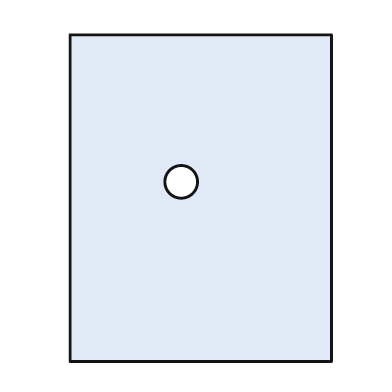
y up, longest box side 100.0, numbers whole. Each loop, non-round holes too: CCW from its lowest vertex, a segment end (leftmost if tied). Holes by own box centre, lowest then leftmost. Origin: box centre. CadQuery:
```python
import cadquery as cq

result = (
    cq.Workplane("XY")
    .moveTo(-40.0, -50.0)
    .lineTo(40.0, -50.0)
    .lineTo(40.0, 50.0)
    .lineTo(-40.0, 50.0)
    .close()
    .moveTo(-6.0, 5.0)
    .circle(5.0)
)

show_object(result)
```